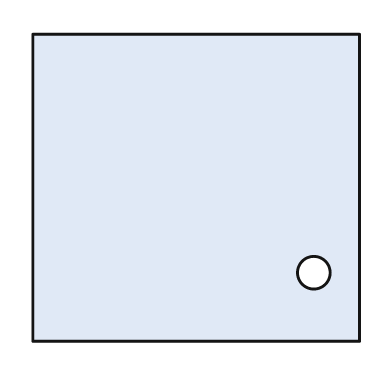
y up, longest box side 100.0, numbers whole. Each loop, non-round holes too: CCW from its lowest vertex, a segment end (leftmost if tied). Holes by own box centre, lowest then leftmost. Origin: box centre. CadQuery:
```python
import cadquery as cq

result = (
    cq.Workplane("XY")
    .moveTo(-50.0, -47.0)
    .lineTo(50.0, -47.0)
    .lineTo(50.0, 47.0)
    .lineTo(-50.0, 47.0)
    .close()
    .moveTo(36.0, -26.0)
    .circle(5.0)
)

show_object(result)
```